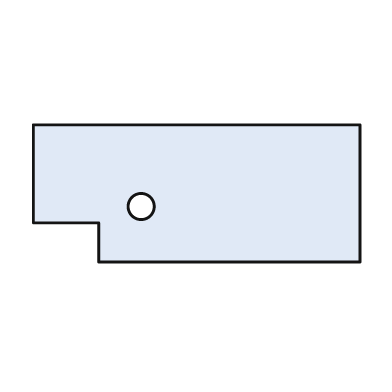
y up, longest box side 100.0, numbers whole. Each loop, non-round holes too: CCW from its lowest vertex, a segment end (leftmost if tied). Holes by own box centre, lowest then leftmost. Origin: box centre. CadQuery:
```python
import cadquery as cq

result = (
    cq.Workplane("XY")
    .moveTo(-30.0, -21.0)
    .lineTo(50.0, -21.0)
    .lineTo(50.0, 21.0)
    .lineTo(-50.0, 21.0)
    .lineTo(-50.0, -9.0)
    .lineTo(-30.0, -9.0)
    .close()
    .moveTo(-17.0, -4.0)
    .circle(4.0)
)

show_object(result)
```